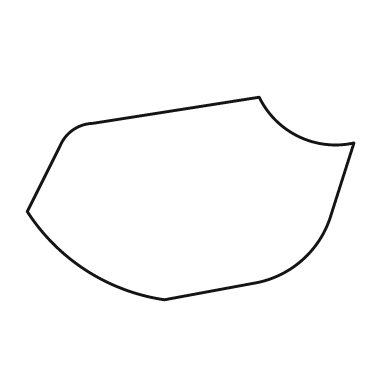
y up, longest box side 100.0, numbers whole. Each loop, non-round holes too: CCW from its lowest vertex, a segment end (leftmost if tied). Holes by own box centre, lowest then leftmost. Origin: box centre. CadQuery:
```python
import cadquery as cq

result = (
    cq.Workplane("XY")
    .moveTo(-8.0, -31.0)
    .lineTo(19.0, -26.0)
    .threePointArc((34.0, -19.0), (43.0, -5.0))
    .lineTo(50.0, 17.0)
    .threePointArc((33.0, 19.0), (21.0, 31.0))
    .lineTo(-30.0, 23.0)
    .threePointArc((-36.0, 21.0), (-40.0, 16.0))
    .lineTo(-50.0, -4.0)
    .threePointArc((-32.0, -22.0), (-8.0, -31.0))
    .close()
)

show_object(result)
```